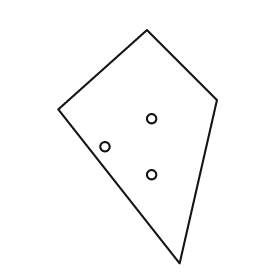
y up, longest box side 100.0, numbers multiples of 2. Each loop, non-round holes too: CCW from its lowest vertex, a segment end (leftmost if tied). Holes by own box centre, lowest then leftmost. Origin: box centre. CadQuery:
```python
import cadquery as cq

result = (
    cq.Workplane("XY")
    .moveTo(18.0, -50.0)
    .lineTo(34.0, 20.0)
    .lineTo(4.0, 50.0)
    .lineTo(-34.0, 16.0)
    .close()
    .moveTo(6.0, -12.0)
    .circle(2.0)
    .moveTo(-14.0, 0.0)
    .circle(2.0)
    .moveTo(6.0, 12.0)
    .circle(2.0)
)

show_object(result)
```